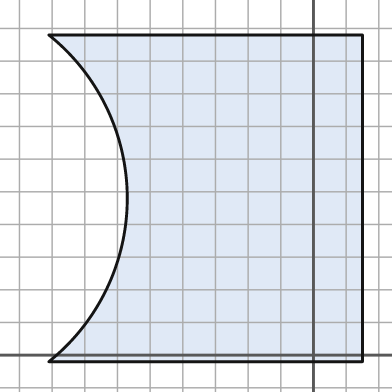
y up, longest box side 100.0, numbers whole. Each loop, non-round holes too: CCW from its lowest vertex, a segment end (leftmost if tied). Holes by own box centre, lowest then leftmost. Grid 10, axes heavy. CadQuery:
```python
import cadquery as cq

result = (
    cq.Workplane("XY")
    .moveTo(-81.0, -2.0)
    .lineTo(15.0, -2.0)
    .lineTo(15.0, 98.0)
    .lineTo(-81.0, 98.0)
    .threePointArc((-57.0, 48.0), (-81.0, -2.0))
    .close()
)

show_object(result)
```